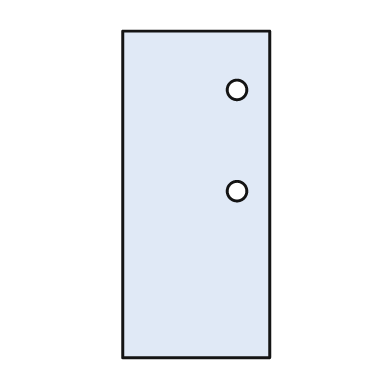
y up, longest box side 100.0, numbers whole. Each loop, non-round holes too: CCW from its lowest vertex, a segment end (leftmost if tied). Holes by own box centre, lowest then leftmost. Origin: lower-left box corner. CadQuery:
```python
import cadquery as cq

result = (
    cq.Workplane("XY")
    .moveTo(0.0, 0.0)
    .lineTo(45.0, 0.0)
    .lineTo(45.0, 100.0)
    .lineTo(0.0, 100.0)
    .close()
    .moveTo(35.0, 51.0)
    .circle(3.0)
    .moveTo(35.0, 82.0)
    .circle(3.0)
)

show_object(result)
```